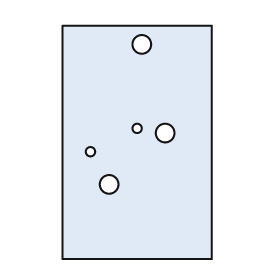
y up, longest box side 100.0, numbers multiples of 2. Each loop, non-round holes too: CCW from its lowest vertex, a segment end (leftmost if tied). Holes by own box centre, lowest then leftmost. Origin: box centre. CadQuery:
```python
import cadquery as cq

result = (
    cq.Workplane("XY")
    .moveTo(-32.0, -50.0)
    .lineTo(32.0, -50.0)
    .lineTo(32.0, 50.0)
    .lineTo(-32.0, 50.0)
    .close()
    .moveTo(-12.0, -18.0)
    .circle(4.0)
    .moveTo(-20.0, -4.0)
    .circle(2.0)
    .moveTo(12.0, 4.0)
    .circle(4.0)
    .moveTo(0.0, 6.0)
    .circle(2.0)
    .moveTo(2.0, 42.0)
    .circle(4.0)
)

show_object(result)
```